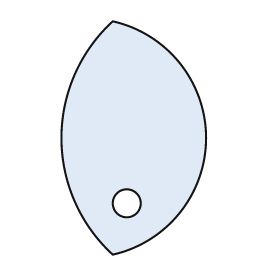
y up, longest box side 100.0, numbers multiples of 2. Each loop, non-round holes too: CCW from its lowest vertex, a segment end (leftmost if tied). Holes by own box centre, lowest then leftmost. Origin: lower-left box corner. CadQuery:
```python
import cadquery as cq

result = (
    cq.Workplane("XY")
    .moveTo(22.0, 0.0)
    .threePointArc((62.0, 50.0), (22.0, 100.0))
    .threePointArc((0.0, 50.0), (22.0, 0.0))
    .close()
    .moveTo(28.0, 22.0)
    .circle(6.0)
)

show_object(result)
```